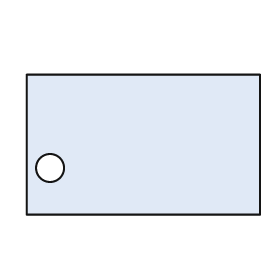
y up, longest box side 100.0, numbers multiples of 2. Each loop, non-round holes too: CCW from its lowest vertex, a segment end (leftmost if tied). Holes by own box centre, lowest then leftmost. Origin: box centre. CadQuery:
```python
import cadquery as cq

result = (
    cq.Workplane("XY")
    .moveTo(-50.0, -30.0)
    .lineTo(50.0, -30.0)
    .lineTo(50.0, 30.0)
    .lineTo(-50.0, 30.0)
    .close()
    .moveTo(-40.0, -10.0)
    .circle(6.0)
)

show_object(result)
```